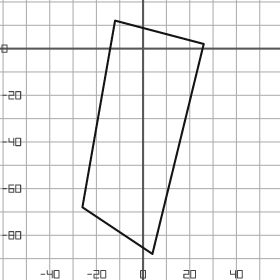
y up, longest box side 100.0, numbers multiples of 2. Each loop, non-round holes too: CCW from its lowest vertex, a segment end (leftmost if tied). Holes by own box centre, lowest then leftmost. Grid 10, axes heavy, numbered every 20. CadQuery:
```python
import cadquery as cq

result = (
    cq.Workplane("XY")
    .moveTo(4.0, -88.0)
    .lineTo(26.0, 2.0)
    .lineTo(-12.0, 12.0)
    .lineTo(-26.0, -68.0)
    .close()
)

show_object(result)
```